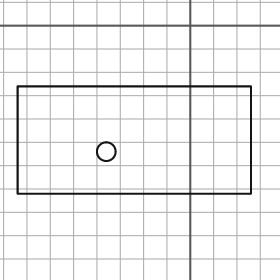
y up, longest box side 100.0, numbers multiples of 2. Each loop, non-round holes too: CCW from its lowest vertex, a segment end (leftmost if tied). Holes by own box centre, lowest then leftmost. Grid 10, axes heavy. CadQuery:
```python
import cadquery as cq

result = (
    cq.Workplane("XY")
    .moveTo(-74.0, -72.0)
    .lineTo(26.0, -72.0)
    .lineTo(26.0, -26.0)
    .lineTo(-74.0, -26.0)
    .close()
    .moveTo(-36.0, -54.0)
    .circle(4.0)
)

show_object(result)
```